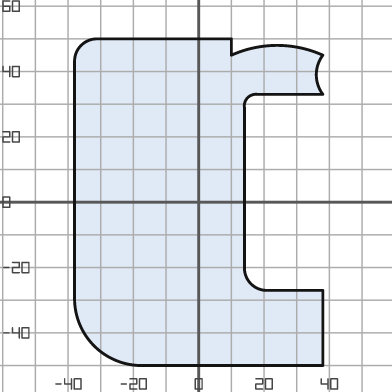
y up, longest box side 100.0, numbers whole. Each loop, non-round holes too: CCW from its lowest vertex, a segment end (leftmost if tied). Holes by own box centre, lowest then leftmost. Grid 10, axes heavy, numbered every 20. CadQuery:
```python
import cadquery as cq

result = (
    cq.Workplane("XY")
    .moveTo(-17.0, -50.0)
    .lineTo(38.0, -50.0)
    .lineTo(38.0, -27.0)
    .lineTo(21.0, -27.0)
    .threePointArc((16.0, -25.0), (14.0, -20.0))
    .lineTo(14.0, 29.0)
    .threePointArc((15.0, 32.0), (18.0, 33.0))
    .lineTo(38.0, 33.0)
    .threePointArc((36.0, 39.0), (38.0, 45.0))
    .threePointArc((24.0, 48.0), (10.0, 45.0))
    .lineTo(10.0, 50.0)
    .lineTo(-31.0, 50.0)
    .threePointArc((-36.0, 48.0), (-38.0, 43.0))
    .lineTo(-38.0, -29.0)
    .threePointArc((-32.0, -44.0), (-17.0, -50.0))
    .close()
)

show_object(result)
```